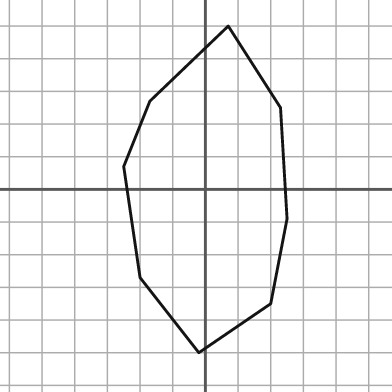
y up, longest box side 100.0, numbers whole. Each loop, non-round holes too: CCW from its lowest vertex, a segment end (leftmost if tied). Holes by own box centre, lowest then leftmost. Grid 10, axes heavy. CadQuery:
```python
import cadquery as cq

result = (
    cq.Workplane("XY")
    .moveTo(-2.0, -50.0)
    .lineTo(20.0, -35.0)
    .lineTo(25.0, -9.0)
    .lineTo(23.0, 25.0)
    .lineTo(7.0, 50.0)
    .lineTo(-17.0, 27.0)
    .lineTo(-25.0, 7.0)
    .lineTo(-20.0, -27.0)
    .close()
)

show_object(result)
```